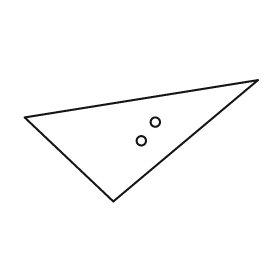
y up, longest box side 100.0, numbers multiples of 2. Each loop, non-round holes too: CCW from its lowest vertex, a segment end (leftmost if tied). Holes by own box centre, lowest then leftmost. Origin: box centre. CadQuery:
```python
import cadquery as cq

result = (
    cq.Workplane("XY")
    .moveTo(-12.0, -26.0)
    .lineTo(50.0, 26.0)
    .lineTo(-50.0, 10.0)
    .close()
    .moveTo(0.0, 0.0)
    .circle(2.0)
    .moveTo(6.0, 8.0)
    .circle(2.0)
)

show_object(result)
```